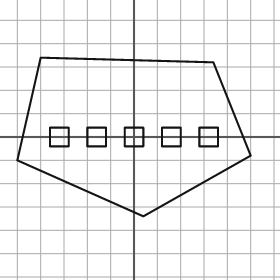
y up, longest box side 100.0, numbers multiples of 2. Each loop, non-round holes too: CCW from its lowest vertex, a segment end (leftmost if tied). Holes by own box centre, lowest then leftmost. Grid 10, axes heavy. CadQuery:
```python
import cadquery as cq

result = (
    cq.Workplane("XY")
    .moveTo(4.0, -34.0)
    .lineTo(50.0, -8.0)
    .lineTo(34.0, 32.0)
    .lineTo(-40.0, 34.0)
    .lineTo(-50.0, -10.0)
    .close()
    .moveTo(-36.0, -4.0)
    .lineTo(-28.0, -4.0)
    .lineTo(-28.0, 4.0)
    .lineTo(-36.0, 4.0)
    .close()
    .moveTo(-20.0, -4.0)
    .lineTo(-12.0, -4.0)
    .lineTo(-12.0, 4.0)
    .lineTo(-20.0, 4.0)
    .close()
    .moveTo(-4.0, -4.0)
    .lineTo(4.0, -4.0)
    .lineTo(4.0, 4.0)
    .lineTo(-4.0, 4.0)
    .close()
    .moveTo(12.0, -4.0)
    .lineTo(20.0, -4.0)
    .lineTo(20.0, 4.0)
    .lineTo(12.0, 4.0)
    .close()
    .moveTo(28.0, -4.0)
    .lineTo(36.0, -4.0)
    .lineTo(36.0, 4.0)
    .lineTo(28.0, 4.0)
    .close()
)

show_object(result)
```